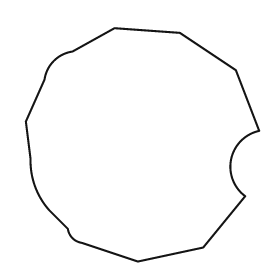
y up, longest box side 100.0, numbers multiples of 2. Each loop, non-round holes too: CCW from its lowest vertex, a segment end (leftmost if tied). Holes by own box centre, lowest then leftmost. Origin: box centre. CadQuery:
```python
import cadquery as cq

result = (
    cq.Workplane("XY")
    .moveTo(-2.0, -50.0)
    .lineTo(26.0, -44.0)
    .lineTo(44.0, -22.0)
    .threePointArc((38.0, -6.0), (50.0, 6.0))
    .lineTo(40.0, 32.0)
    .lineTo(16.0, 48.0)
    .lineTo(-12.0, 50.0)
    .lineTo(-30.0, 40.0)
    .threePointArc((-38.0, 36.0), (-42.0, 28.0))
    .lineTo(-50.0, 10.0)
    .lineTo(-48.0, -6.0)
    .threePointArc((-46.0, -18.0), (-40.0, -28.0))
    .lineTo(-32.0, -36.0)
    .threePointArc((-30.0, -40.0), (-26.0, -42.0))
    .close()
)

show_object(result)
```